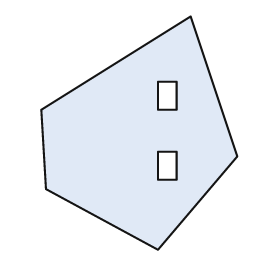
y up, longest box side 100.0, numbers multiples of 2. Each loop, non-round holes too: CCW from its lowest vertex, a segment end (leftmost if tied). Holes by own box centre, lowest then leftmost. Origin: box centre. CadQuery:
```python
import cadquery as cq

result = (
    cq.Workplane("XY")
    .moveTo(8.0, -50.0)
    .lineTo(42.0, -10.0)
    .lineTo(22.0, 50.0)
    .lineTo(-42.0, 10.0)
    .lineTo(-40.0, -24.0)
    .close()
    .moveTo(8.0, -20.0)
    .lineTo(16.0, -20.0)
    .lineTo(16.0, -8.0)
    .lineTo(8.0, -8.0)
    .close()
    .moveTo(8.0, 10.0)
    .lineTo(16.0, 10.0)
    .lineTo(16.0, 22.0)
    .lineTo(8.0, 22.0)
    .close()
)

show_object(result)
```